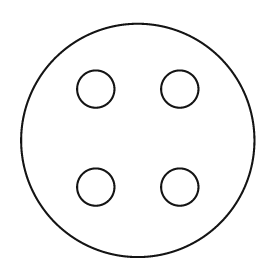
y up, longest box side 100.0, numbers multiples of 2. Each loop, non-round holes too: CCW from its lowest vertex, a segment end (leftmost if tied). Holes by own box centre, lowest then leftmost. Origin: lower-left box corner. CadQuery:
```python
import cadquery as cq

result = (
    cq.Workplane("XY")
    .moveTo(50.0, 50.0)
    .circle(50.0)
    .moveTo(32.0, 30.0)
    .circle(8.0)
    .moveTo(68.0, 30.0)
    .circle(8.0)
    .moveTo(32.0, 72.0)
    .circle(8.0)
    .moveTo(68.0, 72.0)
    .circle(8.0)
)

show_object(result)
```